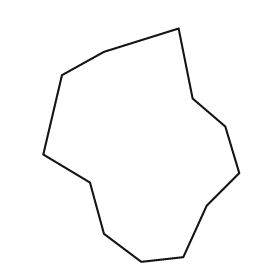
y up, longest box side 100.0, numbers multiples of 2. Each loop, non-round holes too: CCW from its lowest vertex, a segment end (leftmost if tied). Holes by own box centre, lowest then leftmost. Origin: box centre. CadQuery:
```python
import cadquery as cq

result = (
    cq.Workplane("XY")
    .moveTo(0.0, -50.0)
    .lineTo(18.0, -48.0)
    .lineTo(28.0, -26.0)
    .lineTo(42.0, -12.0)
    .lineTo(36.0, 8.0)
    .lineTo(22.0, 20.0)
    .lineTo(16.0, 50.0)
    .lineTo(-16.0, 40.0)
    .lineTo(-34.0, 30.0)
    .lineTo(-42.0, -4.0)
    .lineTo(-22.0, -16.0)
    .lineTo(-16.0, -38.0)
    .close()
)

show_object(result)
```